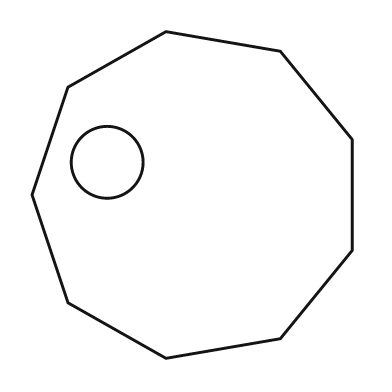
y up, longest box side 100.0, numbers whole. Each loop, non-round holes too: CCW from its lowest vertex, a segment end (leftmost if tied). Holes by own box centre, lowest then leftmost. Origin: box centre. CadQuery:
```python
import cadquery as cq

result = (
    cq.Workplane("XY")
    .moveTo(-8.0, -50.0)
    .lineTo(27.0, -44.0)
    .lineTo(49.0, -17.0)
    .lineTo(49.0, 17.0)
    .lineTo(27.0, 44.0)
    .lineTo(-8.0, 50.0)
    .lineTo(-38.0, 33.0)
    .lineTo(-49.0, 0.0)
    .lineTo(-38.0, -33.0)
    .close()
    .moveTo(-26.0, 10.0)
    .circle(11.0)
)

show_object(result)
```